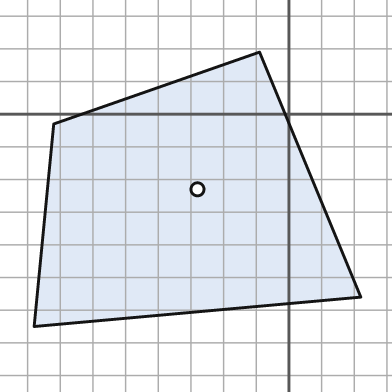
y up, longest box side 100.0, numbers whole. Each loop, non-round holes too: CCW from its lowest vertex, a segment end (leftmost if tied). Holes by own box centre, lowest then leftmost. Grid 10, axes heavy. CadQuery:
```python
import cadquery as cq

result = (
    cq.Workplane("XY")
    .moveTo(-78.0, -65.0)
    .lineTo(22.0, -56.0)
    .lineTo(-9.0, 19.0)
    .lineTo(-72.0, -3.0)
    .close()
    .moveTo(-28.0, -23.0)
    .circle(2.0)
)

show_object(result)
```